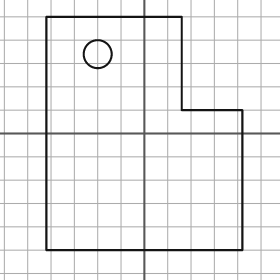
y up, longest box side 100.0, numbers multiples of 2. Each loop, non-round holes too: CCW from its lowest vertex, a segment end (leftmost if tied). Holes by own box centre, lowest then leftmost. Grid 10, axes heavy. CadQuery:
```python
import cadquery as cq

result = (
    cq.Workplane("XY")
    .moveTo(-42.0, -50.0)
    .lineTo(42.0, -50.0)
    .lineTo(42.0, 10.0)
    .lineTo(16.0, 10.0)
    .lineTo(16.0, 50.0)
    .lineTo(-42.0, 50.0)
    .close()
    .moveTo(-20.0, 34.0)
    .circle(6.0)
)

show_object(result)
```